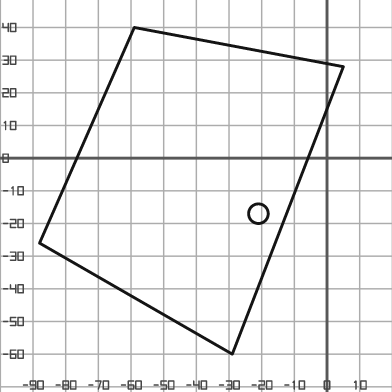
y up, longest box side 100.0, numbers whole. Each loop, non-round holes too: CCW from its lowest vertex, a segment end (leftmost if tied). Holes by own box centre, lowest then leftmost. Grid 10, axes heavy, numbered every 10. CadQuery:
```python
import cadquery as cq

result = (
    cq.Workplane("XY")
    .moveTo(-29.0, -60.0)
    .lineTo(5.0, 28.0)
    .lineTo(-59.0, 40.0)
    .lineTo(-88.0, -26.0)
    .close()
    .moveTo(-21.0, -17.0)
    .circle(3.0)
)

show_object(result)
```